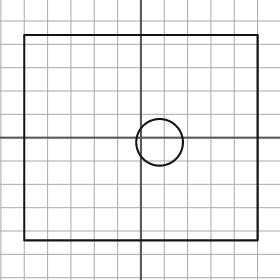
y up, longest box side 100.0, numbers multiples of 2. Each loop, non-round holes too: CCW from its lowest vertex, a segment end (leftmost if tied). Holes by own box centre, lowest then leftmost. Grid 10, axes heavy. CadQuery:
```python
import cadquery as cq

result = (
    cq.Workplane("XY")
    .moveTo(-50.0, -44.0)
    .lineTo(50.0, -44.0)
    .lineTo(50.0, 44.0)
    .lineTo(-50.0, 44.0)
    .close()
    .moveTo(8.0, -2.0)
    .circle(10.0)
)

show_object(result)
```